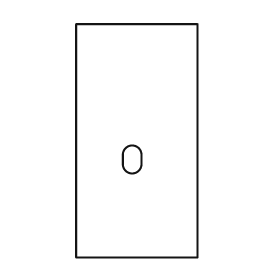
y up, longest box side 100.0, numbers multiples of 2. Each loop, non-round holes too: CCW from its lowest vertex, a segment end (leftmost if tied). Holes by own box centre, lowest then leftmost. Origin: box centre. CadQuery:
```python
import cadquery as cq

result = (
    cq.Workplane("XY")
    .moveTo(-26.0, -50.0)
    .lineTo(26.0, -50.0)
    .lineTo(26.0, 50.0)
    .lineTo(-26.0, 50.0)
    .close()
    .moveTo(-6.0, -10.0)
    .threePointArc((-2.0, -14.0), (2.0, -10.0))
    .lineTo(2.0, -6.0)
    .threePointArc((-2.0, -2.0), (-6.0, -6.0))
    .close()
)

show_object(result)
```